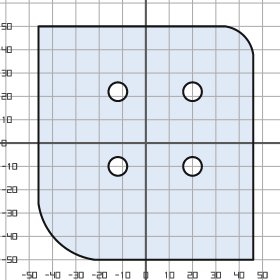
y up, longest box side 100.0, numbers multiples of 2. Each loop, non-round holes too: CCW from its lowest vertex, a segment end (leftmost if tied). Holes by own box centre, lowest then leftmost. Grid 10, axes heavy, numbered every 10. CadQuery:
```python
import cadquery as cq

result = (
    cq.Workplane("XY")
    .moveTo(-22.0, -50.0)
    .lineTo(46.0, -50.0)
    .lineTo(46.0, 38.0)
    .threePointArc((42.0, 46.0), (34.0, 50.0))
    .lineTo(-46.0, 50.0)
    .lineTo(-46.0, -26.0)
    .threePointArc((-38.0, -42.0), (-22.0, -50.0))
    .close()
    .moveTo(-12.0, -10.0)
    .circle(4.0)
    .moveTo(20.0, -10.0)
    .circle(4.0)
    .moveTo(-12.0, 22.0)
    .circle(4.0)
    .moveTo(20.0, 22.0)
    .circle(4.0)
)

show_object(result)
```